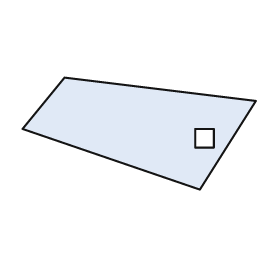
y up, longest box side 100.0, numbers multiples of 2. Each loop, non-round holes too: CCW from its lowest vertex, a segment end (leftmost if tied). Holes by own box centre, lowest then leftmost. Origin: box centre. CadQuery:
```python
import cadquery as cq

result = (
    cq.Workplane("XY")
    .moveTo(26.0, -24.0)
    .lineTo(50.0, 14.0)
    .lineTo(-32.0, 24.0)
    .lineTo(-50.0, 2.0)
    .close()
    .moveTo(24.0, -6.0)
    .lineTo(32.0, -6.0)
    .lineTo(32.0, 2.0)
    .lineTo(24.0, 2.0)
    .close()
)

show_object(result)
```